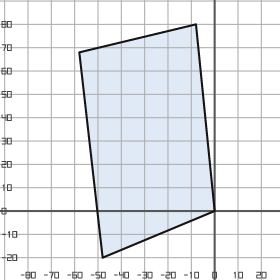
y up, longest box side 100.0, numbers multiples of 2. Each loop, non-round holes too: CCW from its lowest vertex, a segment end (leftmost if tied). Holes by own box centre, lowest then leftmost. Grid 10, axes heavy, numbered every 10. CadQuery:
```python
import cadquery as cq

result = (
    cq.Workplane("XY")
    .moveTo(-48.0, -20.0)
    .lineTo(0.0, 0.0)
    .lineTo(-8.0, 80.0)
    .lineTo(-58.0, 68.0)
    .close()
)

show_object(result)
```